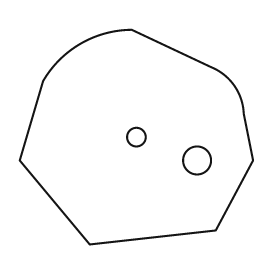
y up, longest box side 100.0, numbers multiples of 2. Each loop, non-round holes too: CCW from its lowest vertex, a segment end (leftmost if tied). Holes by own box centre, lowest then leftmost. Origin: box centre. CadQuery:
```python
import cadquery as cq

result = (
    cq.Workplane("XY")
    .moveTo(-20.0, -46.0)
    .lineTo(34.0, -40.0)
    .lineTo(50.0, -10.0)
    .lineTo(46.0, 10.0)
    .threePointArc((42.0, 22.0), (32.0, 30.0))
    .lineTo(-2.0, 46.0)
    .threePointArc((-24.0, 40.0), (-40.0, 24.0))
    .lineTo(-50.0, -10.0)
    .close()
    .moveTo(26.0, -10.0)
    .circle(6.0)
    .moveTo(0.0, 0.0)
    .circle(4.0)
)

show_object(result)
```